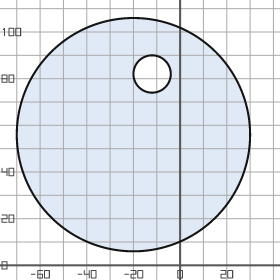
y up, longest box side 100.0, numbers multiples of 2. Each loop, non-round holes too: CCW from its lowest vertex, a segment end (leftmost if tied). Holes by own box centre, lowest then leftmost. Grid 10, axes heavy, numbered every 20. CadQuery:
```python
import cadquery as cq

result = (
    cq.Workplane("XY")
    .moveTo(-20.0, 56.0)
    .circle(50.0)
    .moveTo(-12.0, 82.0)
    .circle(8.0)
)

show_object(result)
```